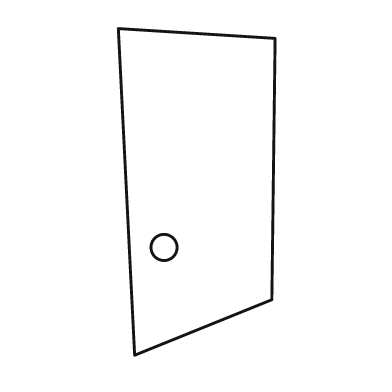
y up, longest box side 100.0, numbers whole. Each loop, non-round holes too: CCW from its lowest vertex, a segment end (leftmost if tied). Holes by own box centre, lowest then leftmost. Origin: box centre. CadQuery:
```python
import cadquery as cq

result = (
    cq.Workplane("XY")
    .moveTo(-19.0, -50.0)
    .lineTo(23.0, -33.0)
    .lineTo(24.0, 47.0)
    .lineTo(-24.0, 50.0)
    .close()
    .moveTo(-10.0, -17.0)
    .circle(4.0)
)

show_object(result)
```